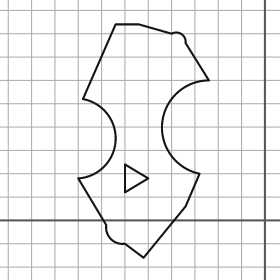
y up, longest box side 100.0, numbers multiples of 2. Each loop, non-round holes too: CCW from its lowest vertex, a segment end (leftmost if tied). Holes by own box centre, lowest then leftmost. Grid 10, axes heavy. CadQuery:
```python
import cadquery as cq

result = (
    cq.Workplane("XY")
    .moveTo(-52.0, -16.0)
    .lineTo(-34.0, 6.0)
    .lineTo(-28.0, 20.0)
    .threePointArc((-44.0, 42.0), (-24.0, 60.0))
    .lineTo(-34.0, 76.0)
    .threePointArc((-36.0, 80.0), (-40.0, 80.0))
    .lineTo(-54.0, 84.0)
    .lineTo(-64.0, 84.0)
    .lineTo(-78.0, 52.0)
    .threePointArc((-64.0, 34.0), (-80.0, 18.0))
    .lineTo(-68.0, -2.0)
    .threePointArc((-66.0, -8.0), (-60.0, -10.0))
    .close()
    .moveTo(-60.0, 12.0)
    .lineTo(-50.0, 18.0)
    .lineTo(-60.0, 24.0)
    .close()
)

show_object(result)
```